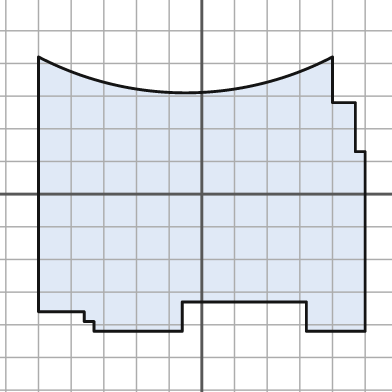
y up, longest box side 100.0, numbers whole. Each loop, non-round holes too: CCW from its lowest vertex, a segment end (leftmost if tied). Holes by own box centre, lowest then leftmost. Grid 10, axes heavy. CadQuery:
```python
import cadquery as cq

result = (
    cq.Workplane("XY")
    .moveTo(-33.0, -42.0)
    .lineTo(-6.0, -42.0)
    .lineTo(-6.0, -33.0)
    .lineTo(32.0, -33.0)
    .lineTo(32.0, -42.0)
    .lineTo(50.0, -42.0)
    .lineTo(50.0, 13.0)
    .lineTo(47.0, 13.0)
    .lineTo(47.0, 28.0)
    .lineTo(40.0, 28.0)
    .lineTo(40.0, 42.0)
    .threePointArc((-5.0, 31.0), (-50.0, 42.0))
    .lineTo(-50.0, -36.0)
    .lineTo(-36.0, -36.0)
    .lineTo(-36.0, -39.0)
    .lineTo(-33.0, -39.0)
    .close()
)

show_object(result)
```